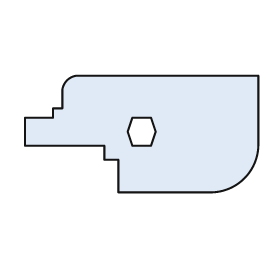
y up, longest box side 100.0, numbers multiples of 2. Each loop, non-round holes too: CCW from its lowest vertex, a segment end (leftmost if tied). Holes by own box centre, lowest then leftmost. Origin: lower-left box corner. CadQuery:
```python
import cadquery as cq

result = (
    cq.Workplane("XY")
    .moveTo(40.0, 0.0)
    .lineTo(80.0, 0.0)
    .threePointArc((94.0, 6.0), (100.0, 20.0))
    .lineTo(100.0, 50.0)
    .lineTo(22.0, 50.0)
    .threePointArc((18.0, 48.0), (16.0, 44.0))
    .lineTo(16.0, 36.0)
    .lineTo(12.0, 36.0)
    .lineTo(12.0, 32.0)
    .lineTo(0.0, 32.0)
    .lineTo(0.0, 20.0)
    .lineTo(34.0, 20.0)
    .lineTo(34.0, 14.0)
    .lineTo(40.0, 14.0)
    .close()
    .moveTo(46.0, 20.0)
    .lineTo(54.0, 20.0)
    .lineTo(56.0, 26.0)
    .lineTo(54.0, 32.0)
    .lineTo(46.0, 32.0)
    .lineTo(44.0, 26.0)
    .close()
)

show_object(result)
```